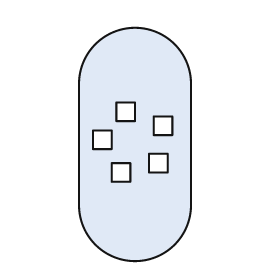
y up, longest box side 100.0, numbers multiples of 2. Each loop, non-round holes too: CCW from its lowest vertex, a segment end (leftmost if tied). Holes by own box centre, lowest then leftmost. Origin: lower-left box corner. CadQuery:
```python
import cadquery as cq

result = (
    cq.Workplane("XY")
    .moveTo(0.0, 24.0)
    .threePointArc((24.0, 0.0), (48.0, 24.0))
    .lineTo(48.0, 76.0)
    .threePointArc((24.0, 100.0), (0.0, 76.0))
    .close()
    .moveTo(14.0, 34.0)
    .lineTo(22.0, 34.0)
    .lineTo(22.0, 42.0)
    .lineTo(14.0, 42.0)
    .close()
    .moveTo(30.0, 38.0)
    .lineTo(38.0, 38.0)
    .lineTo(38.0, 46.0)
    .lineTo(30.0, 46.0)
    .close()
    .moveTo(6.0, 48.0)
    .lineTo(14.0, 48.0)
    .lineTo(14.0, 56.0)
    .lineTo(6.0, 56.0)
    .close()
    .moveTo(32.0, 54.0)
    .lineTo(40.0, 54.0)
    .lineTo(40.0, 62.0)
    .lineTo(32.0, 62.0)
    .close()
    .moveTo(16.0, 60.0)
    .lineTo(24.0, 60.0)
    .lineTo(24.0, 68.0)
    .lineTo(16.0, 68.0)
    .close()
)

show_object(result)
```